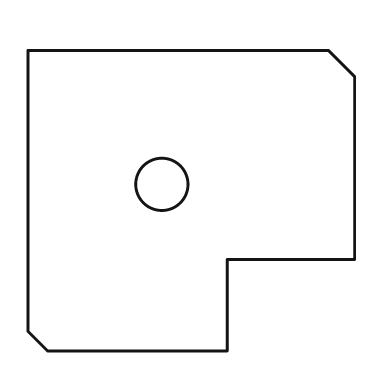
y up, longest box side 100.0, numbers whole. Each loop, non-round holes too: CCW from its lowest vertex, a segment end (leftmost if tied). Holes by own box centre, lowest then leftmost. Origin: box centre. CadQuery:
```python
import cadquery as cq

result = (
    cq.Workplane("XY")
    .moveTo(-44.0, -46.0)
    .lineTo(11.0, -46.0)
    .lineTo(11.0, -18.0)
    .lineTo(50.0, -18.0)
    .lineTo(50.0, 38.0)
    .lineTo(42.0, 46.0)
    .lineTo(-50.0, 46.0)
    .lineTo(-50.0, -40.0)
    .close()
    .moveTo(-9.0, 5.0)
    .circle(8.0)
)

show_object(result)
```